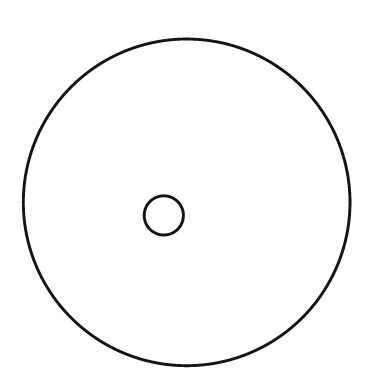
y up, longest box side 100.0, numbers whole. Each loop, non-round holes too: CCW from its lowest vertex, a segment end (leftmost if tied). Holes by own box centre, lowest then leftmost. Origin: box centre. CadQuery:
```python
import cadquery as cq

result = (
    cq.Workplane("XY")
    .moveTo(0.0, 0.0)
    .circle(50.0)
    .moveTo(-7.0, -4.0)
    .circle(6.0)
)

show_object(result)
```